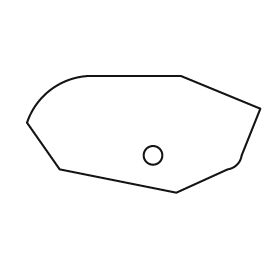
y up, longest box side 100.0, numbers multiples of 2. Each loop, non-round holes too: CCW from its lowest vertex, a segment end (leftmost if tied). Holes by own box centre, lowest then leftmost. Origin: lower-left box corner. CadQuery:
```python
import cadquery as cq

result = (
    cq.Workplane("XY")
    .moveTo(64.0, 0.0)
    .lineTo(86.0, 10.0)
    .threePointArc((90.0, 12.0), (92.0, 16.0))
    .lineTo(100.0, 36.0)
    .lineTo(66.0, 50.0)
    .lineTo(26.0, 50.0)
    .threePointArc((10.0, 44.0), (0.0, 30.0))
    .lineTo(14.0, 10.0)
    .close()
    .moveTo(54.0, 16.0)
    .circle(4.0)
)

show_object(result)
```